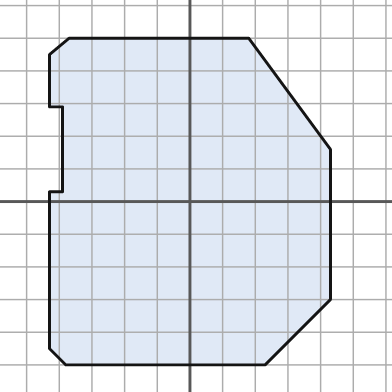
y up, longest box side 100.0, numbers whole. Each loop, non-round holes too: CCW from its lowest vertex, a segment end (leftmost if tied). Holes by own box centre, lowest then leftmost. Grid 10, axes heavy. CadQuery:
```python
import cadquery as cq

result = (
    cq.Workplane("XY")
    .moveTo(-38.0, -50.0)
    .lineTo(23.0, -50.0)
    .lineTo(43.0, -30.0)
    .lineTo(43.0, 16.0)
    .lineTo(18.0, 50.0)
    .lineTo(-37.0, 50.0)
    .lineTo(-43.0, 45.0)
    .lineTo(-43.0, 29.0)
    .lineTo(-39.0, 29.0)
    .lineTo(-39.0, 3.0)
    .lineTo(-43.0, 3.0)
    .lineTo(-43.0, -45.0)
    .close()
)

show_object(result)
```